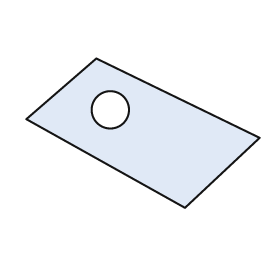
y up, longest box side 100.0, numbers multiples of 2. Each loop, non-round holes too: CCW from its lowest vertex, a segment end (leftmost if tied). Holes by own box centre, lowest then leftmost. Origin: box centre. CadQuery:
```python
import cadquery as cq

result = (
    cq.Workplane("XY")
    .moveTo(18.0, -32.0)
    .lineTo(50.0, -2.0)
    .lineTo(-20.0, 32.0)
    .lineTo(-50.0, 6.0)
    .close()
    .moveTo(-14.0, 10.0)
    .circle(8.0)
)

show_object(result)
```